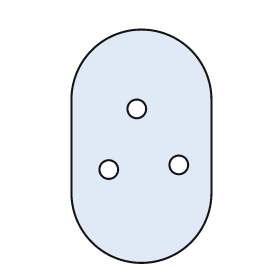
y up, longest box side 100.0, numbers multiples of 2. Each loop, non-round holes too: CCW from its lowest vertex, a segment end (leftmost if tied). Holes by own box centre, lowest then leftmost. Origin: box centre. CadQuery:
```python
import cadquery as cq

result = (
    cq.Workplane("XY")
    .moveTo(-30.0, -20.0)
    .threePointArc((0.0, -50.0), (30.0, -20.0))
    .lineTo(30.0, 20.0)
    .threePointArc((0.0, 50.0), (-30.0, 20.0))
    .close()
    .moveTo(-14.0, -10.0)
    .circle(4.0)
    .moveTo(16.0, -8.0)
    .circle(4.0)
    .moveTo(-2.0, 16.0)
    .circle(4.0)
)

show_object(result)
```